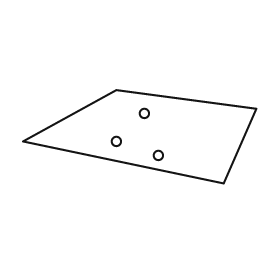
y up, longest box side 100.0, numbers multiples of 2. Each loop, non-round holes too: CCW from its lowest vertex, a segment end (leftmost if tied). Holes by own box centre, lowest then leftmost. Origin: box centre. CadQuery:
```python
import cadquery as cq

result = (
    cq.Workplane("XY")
    .moveTo(36.0, -20.0)
    .lineTo(50.0, 12.0)
    .lineTo(-10.0, 20.0)
    .lineTo(-50.0, -2.0)
    .close()
    .moveTo(8.0, -8.0)
    .circle(2.0)
    .moveTo(-10.0, -2.0)
    .circle(2.0)
    .moveTo(2.0, 10.0)
    .circle(2.0)
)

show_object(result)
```